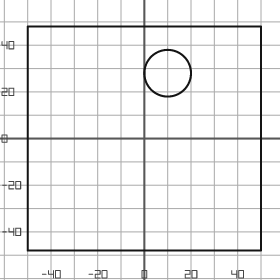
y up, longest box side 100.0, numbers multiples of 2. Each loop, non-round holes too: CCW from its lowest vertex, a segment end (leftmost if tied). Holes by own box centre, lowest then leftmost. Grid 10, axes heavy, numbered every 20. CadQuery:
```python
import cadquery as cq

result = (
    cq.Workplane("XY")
    .moveTo(-50.0, -48.0)
    .lineTo(50.0, -48.0)
    .lineTo(50.0, 48.0)
    .lineTo(-50.0, 48.0)
    .close()
    .moveTo(10.0, 28.0)
    .circle(10.0)
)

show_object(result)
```